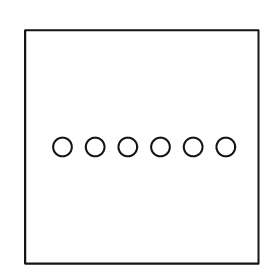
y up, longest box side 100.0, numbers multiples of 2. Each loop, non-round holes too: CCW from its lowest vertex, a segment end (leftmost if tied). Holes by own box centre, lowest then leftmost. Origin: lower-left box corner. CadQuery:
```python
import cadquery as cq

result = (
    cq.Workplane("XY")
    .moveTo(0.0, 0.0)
    .lineTo(100.0, 0.0)
    .lineTo(100.0, 100.0)
    .lineTo(0.0, 100.0)
    .close()
    .moveTo(16.0, 50.0)
    .circle(4.0)
    .moveTo(30.0, 50.0)
    .circle(4.0)
    .moveTo(44.0, 50.0)
    .circle(4.0)
    .moveTo(58.0, 50.0)
    .circle(4.0)
    .moveTo(72.0, 50.0)
    .circle(4.0)
    .moveTo(86.0, 50.0)
    .circle(4.0)
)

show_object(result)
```